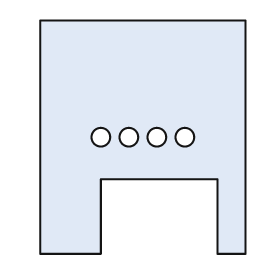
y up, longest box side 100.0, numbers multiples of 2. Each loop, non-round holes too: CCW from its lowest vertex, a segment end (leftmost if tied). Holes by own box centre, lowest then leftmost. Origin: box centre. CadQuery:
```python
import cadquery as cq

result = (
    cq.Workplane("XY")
    .moveTo(-44.0, -50.0)
    .lineTo(-18.0, -50.0)
    .lineTo(-18.0, -18.0)
    .lineTo(32.0, -18.0)
    .lineTo(32.0, -50.0)
    .lineTo(44.0, -50.0)
    .lineTo(44.0, 50.0)
    .lineTo(-44.0, 50.0)
    .close()
    .moveTo(-18.0, 0.0)
    .circle(4.0)
    .moveTo(-6.0, 0.0)
    .circle(4.0)
    .moveTo(6.0, 0.0)
    .circle(4.0)
    .moveTo(18.0, 0.0)
    .circle(4.0)
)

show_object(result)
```